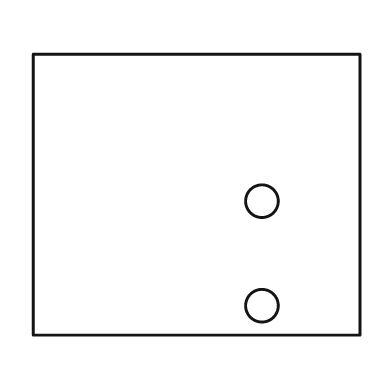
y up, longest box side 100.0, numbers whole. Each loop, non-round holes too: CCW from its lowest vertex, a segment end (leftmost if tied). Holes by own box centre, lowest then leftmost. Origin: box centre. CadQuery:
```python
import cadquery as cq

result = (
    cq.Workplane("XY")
    .moveTo(-50.0, -43.0)
    .lineTo(50.0, -43.0)
    .lineTo(50.0, 43.0)
    .lineTo(-50.0, 43.0)
    .close()
    .moveTo(20.0, -34.0)
    .circle(5.0)
    .moveTo(20.0, -2.0)
    .circle(5.0)
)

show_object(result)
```